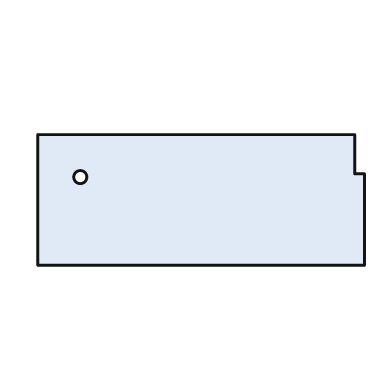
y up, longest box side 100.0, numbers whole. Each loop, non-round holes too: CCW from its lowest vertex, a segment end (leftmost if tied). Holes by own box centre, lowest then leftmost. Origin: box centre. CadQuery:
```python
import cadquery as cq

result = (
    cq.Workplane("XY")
    .moveTo(-50.0, -20.0)
    .lineTo(50.0, -20.0)
    .lineTo(50.0, 8.0)
    .lineTo(47.0, 8.0)
    .lineTo(47.0, 20.0)
    .lineTo(-50.0, 20.0)
    .close()
    .moveTo(-37.0, 7.0)
    .circle(2.0)
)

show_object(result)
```